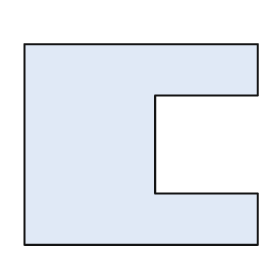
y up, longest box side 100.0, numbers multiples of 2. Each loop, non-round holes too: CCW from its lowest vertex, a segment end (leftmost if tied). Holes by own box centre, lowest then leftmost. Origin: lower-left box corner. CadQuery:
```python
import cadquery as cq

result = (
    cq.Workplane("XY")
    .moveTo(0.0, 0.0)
    .lineTo(100.0, 0.0)
    .lineTo(100.0, 22.0)
    .lineTo(56.0, 22.0)
    .lineTo(56.0, 64.0)
    .lineTo(100.0, 64.0)
    .lineTo(100.0, 86.0)
    .lineTo(0.0, 86.0)
    .close()
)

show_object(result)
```